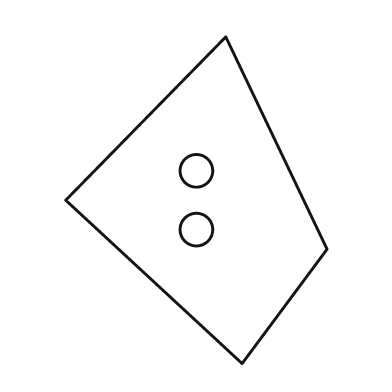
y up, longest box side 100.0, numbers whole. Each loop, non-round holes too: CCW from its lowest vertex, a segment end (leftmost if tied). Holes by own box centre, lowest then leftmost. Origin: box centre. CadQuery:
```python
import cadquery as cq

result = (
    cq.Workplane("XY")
    .moveTo(14.0, -50.0)
    .lineTo(40.0, -15.0)
    .lineTo(9.0, 50.0)
    .lineTo(-40.0, 0.0)
    .close()
    .moveTo(0.0, -9.0)
    .circle(5.0)
    .moveTo(0.0, 9.0)
    .circle(5.0)
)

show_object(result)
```